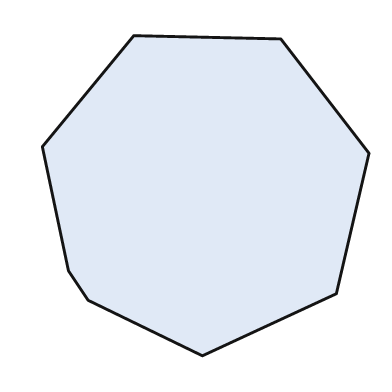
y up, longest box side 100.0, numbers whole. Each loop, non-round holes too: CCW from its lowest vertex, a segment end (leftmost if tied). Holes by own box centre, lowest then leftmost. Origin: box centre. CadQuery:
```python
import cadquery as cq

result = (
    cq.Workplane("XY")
    .moveTo(-1.0, -49.0)
    .lineTo(40.0, -30.0)
    .lineTo(50.0, 13.0)
    .lineTo(23.0, 48.0)
    .lineTo(-22.0, 49.0)
    .lineTo(-50.0, 15.0)
    .lineTo(-42.0, -23.0)
    .lineTo(-36.0, -32.0)
    .close()
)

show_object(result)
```